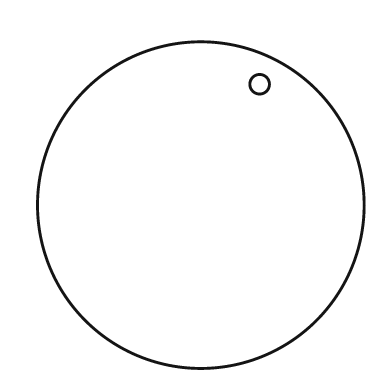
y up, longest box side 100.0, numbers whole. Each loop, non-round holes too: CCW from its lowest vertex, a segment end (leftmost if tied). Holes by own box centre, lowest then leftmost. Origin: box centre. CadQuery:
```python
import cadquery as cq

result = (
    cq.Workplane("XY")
    .moveTo(0.0, 0.0)
    .circle(50.0)
    .moveTo(18.0, 37.0)
    .circle(3.0)
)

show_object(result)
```